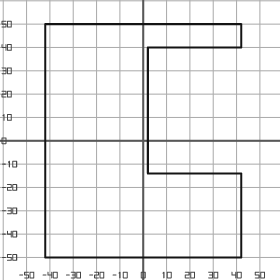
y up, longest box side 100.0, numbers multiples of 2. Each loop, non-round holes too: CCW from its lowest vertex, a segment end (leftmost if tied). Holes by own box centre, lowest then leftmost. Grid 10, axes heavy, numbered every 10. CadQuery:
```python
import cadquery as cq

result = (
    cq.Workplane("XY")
    .moveTo(-42.0, -50.0)
    .lineTo(42.0, -50.0)
    .lineTo(42.0, -14.0)
    .lineTo(2.0, -14.0)
    .lineTo(2.0, 40.0)
    .lineTo(42.0, 40.0)
    .lineTo(42.0, 50.0)
    .lineTo(-42.0, 50.0)
    .close()
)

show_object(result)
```